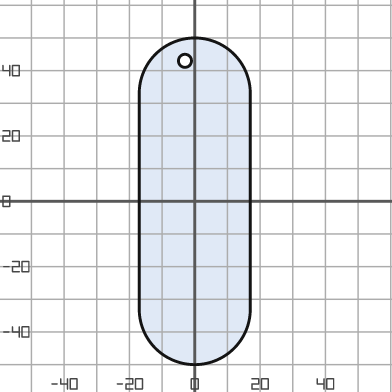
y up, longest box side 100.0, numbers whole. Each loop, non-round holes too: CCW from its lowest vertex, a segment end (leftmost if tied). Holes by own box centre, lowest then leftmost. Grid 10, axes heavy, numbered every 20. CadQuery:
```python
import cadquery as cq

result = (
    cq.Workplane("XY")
    .moveTo(-17.0, -33.0)
    .threePointArc((0.0, -50.0), (17.0, -33.0))
    .lineTo(17.0, 33.0)
    .threePointArc((0.0, 50.0), (-17.0, 33.0))
    .close()
    .moveTo(-3.0, 43.0)
    .circle(2.0)
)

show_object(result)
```